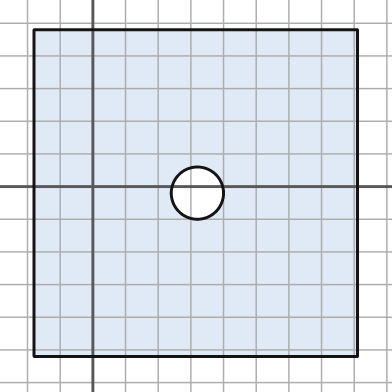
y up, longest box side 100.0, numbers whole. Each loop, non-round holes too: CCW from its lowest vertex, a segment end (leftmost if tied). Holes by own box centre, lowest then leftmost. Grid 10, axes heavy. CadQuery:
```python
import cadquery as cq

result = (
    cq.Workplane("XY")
    .moveTo(-18.0, -52.0)
    .lineTo(81.0, -52.0)
    .lineTo(81.0, 48.0)
    .lineTo(-18.0, 48.0)
    .close()
    .moveTo(32.0, -2.0)
    .circle(8.0)
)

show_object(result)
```